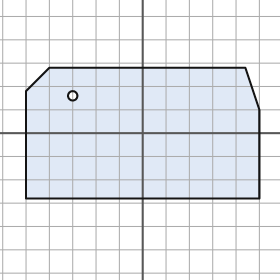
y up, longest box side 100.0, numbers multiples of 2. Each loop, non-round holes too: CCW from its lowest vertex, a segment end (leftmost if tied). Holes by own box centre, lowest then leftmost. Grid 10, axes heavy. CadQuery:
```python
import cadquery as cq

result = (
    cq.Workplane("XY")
    .moveTo(-50.0, -28.0)
    .lineTo(50.0, -28.0)
    .lineTo(50.0, 10.0)
    .lineTo(44.0, 28.0)
    .lineTo(-40.0, 28.0)
    .lineTo(-50.0, 18.0)
    .close()
    .moveTo(-30.0, 16.0)
    .circle(2.0)
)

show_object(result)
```